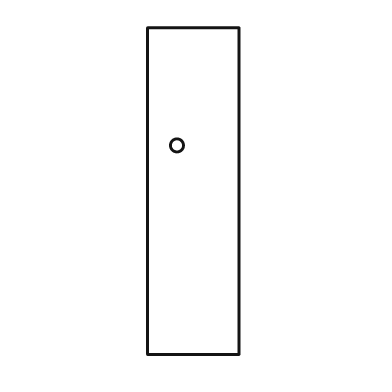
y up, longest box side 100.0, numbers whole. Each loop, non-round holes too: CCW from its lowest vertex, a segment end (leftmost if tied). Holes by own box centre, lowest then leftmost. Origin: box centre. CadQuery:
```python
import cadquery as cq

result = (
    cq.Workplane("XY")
    .moveTo(-14.0, -50.0)
    .lineTo(14.0, -50.0)
    .lineTo(14.0, 50.0)
    .lineTo(-14.0, 50.0)
    .close()
    .moveTo(-5.0, 14.0)
    .circle(2.0)
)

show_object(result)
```